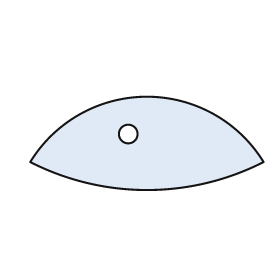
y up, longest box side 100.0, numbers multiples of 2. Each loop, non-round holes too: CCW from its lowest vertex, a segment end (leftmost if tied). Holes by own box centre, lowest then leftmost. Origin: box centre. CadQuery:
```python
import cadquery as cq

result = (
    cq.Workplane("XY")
    .moveTo(-50.0, -8.0)
    .threePointArc((0.0, -20.0), (50.0, -8.0))
    .threePointArc((0.0, 20.0), (-50.0, -8.0))
    .close()
    .moveTo(-8.0, 4.0)
    .circle(4.0)
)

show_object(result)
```